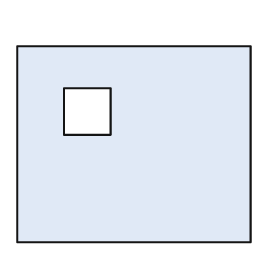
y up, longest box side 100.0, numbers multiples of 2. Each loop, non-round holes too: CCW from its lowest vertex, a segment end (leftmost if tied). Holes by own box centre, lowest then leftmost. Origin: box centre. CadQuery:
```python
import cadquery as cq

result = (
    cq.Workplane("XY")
    .moveTo(-50.0, -42.0)
    .lineTo(50.0, -42.0)
    .lineTo(50.0, 42.0)
    .lineTo(-50.0, 42.0)
    .close()
    .moveTo(-30.0, 4.0)
    .lineTo(-10.0, 4.0)
    .lineTo(-10.0, 24.0)
    .lineTo(-30.0, 24.0)
    .close()
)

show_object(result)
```